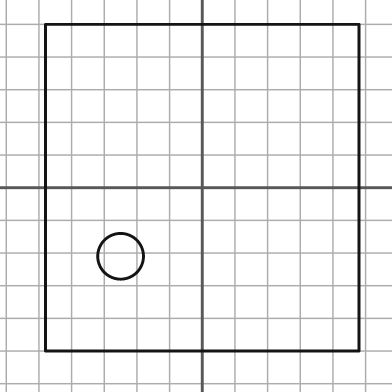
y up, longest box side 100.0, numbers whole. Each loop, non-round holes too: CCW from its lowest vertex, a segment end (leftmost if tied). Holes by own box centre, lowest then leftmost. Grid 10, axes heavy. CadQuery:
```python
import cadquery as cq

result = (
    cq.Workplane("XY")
    .moveTo(-48.0, -50.0)
    .lineTo(48.0, -50.0)
    .lineTo(48.0, 50.0)
    .lineTo(-48.0, 50.0)
    .close()
    .moveTo(-25.0, -21.0)
    .circle(7.0)
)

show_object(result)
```